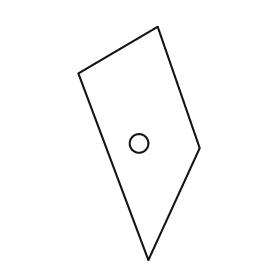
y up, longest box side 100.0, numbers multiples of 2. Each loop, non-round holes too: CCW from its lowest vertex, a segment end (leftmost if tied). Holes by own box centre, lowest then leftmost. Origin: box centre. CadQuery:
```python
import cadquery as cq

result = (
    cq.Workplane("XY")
    .moveTo(4.0, -50.0)
    .lineTo(26.0, -2.0)
    .lineTo(8.0, 50.0)
    .lineTo(-26.0, 30.0)
    .close()
    .moveTo(0.0, 0.0)
    .circle(4.0)
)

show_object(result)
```